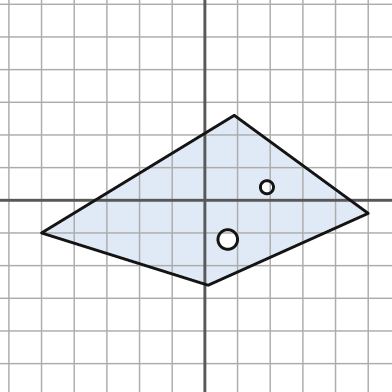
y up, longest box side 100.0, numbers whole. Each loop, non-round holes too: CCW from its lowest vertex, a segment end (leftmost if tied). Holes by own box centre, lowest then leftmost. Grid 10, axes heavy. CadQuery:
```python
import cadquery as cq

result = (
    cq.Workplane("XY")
    .moveTo(1.0, -26.0)
    .lineTo(50.0, -4.0)
    .lineTo(9.0, 26.0)
    .lineTo(-50.0, -10.0)
    .close()
    .moveTo(7.0, -12.0)
    .circle(3.0)
    .moveTo(19.0, 4.0)
    .circle(2.0)
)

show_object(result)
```